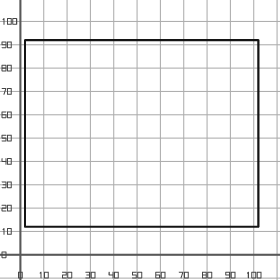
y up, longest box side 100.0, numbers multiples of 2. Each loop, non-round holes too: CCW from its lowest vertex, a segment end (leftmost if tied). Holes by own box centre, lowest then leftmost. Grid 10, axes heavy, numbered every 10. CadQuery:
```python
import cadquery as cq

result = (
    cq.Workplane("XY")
    .moveTo(2.0, 12.0)
    .lineTo(102.0, 12.0)
    .lineTo(102.0, 92.0)
    .lineTo(2.0, 92.0)
    .close()
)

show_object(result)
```